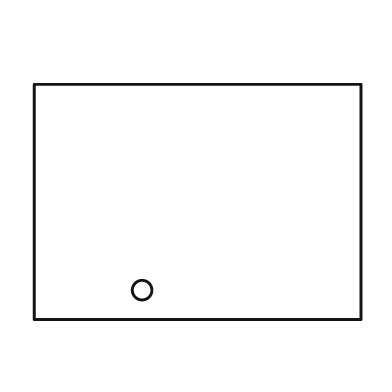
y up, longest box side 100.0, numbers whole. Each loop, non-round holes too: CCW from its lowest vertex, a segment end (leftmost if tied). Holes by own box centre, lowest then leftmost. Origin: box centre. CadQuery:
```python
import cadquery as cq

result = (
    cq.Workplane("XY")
    .moveTo(-50.0, -36.0)
    .lineTo(50.0, -36.0)
    .lineTo(50.0, 36.0)
    .lineTo(-50.0, 36.0)
    .close()
    .moveTo(-17.0, -27.0)
    .circle(3.0)
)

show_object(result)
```